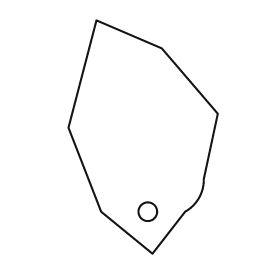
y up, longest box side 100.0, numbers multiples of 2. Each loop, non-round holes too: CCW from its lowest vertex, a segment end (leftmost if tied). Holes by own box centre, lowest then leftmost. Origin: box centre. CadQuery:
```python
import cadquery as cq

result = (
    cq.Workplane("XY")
    .moveTo(4.0, -50.0)
    .lineTo(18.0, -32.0)
    .threePointArc((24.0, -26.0), (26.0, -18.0))
    .lineTo(32.0, 10.0)
    .lineTo(8.0, 38.0)
    .lineTo(-20.0, 50.0)
    .lineTo(-32.0, 4.0)
    .lineTo(-18.0, -32.0)
    .close()
    .moveTo(2.0, -32.0)
    .circle(4.0)
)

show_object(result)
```